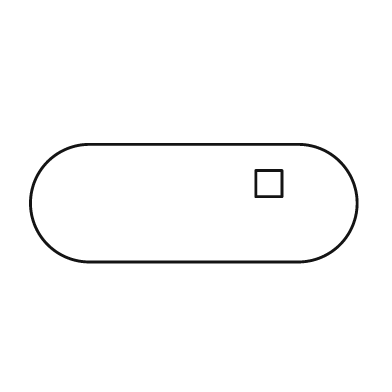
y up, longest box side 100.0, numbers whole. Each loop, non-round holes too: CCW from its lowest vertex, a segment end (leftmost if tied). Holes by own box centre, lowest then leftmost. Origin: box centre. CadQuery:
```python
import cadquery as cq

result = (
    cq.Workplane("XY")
    .moveTo(-32.0, -18.0)
    .lineTo(32.0, -18.0)
    .threePointArc((50.0, 0.0), (32.0, 18.0))
    .lineTo(-32.0, 18.0)
    .threePointArc((-50.0, 0.0), (-32.0, -18.0))
    .close()
    .moveTo(19.0, 2.0)
    .lineTo(27.0, 2.0)
    .lineTo(27.0, 10.0)
    .lineTo(19.0, 10.0)
    .close()
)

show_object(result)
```